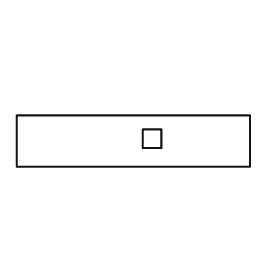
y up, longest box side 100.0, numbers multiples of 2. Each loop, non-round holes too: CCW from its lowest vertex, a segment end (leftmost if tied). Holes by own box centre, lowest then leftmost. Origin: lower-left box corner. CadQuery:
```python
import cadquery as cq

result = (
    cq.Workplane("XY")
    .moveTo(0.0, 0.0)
    .lineTo(100.0, 0.0)
    .lineTo(100.0, 22.0)
    .lineTo(0.0, 22.0)
    .close()
    .moveTo(54.0, 8.0)
    .lineTo(62.0, 8.0)
    .lineTo(62.0, 16.0)
    .lineTo(54.0, 16.0)
    .close()
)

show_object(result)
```